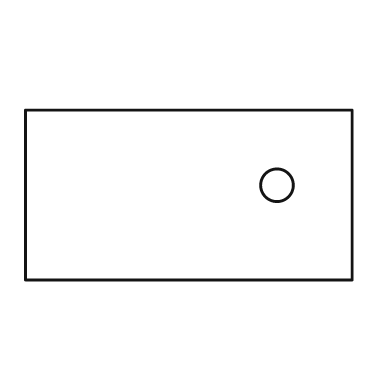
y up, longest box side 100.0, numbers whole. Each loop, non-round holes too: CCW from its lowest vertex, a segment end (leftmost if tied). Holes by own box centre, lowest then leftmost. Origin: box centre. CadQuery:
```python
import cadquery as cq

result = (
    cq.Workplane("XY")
    .moveTo(-50.0, -26.0)
    .lineTo(50.0, -26.0)
    .lineTo(50.0, 26.0)
    .lineTo(-50.0, 26.0)
    .close()
    .moveTo(27.0, 3.0)
    .circle(5.0)
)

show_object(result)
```